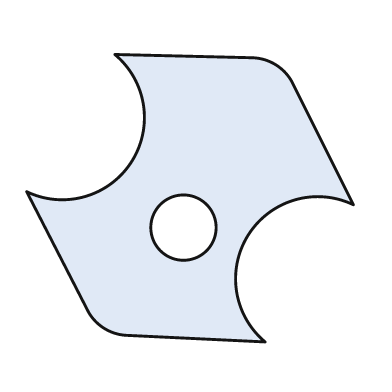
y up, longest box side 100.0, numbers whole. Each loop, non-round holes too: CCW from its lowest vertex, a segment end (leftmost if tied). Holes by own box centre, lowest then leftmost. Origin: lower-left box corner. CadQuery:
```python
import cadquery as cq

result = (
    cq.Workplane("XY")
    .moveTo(73.0, 0.0)
    .threePointArc((68.0, 33.0), (100.0, 42.0))
    .lineTo(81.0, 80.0)
    .threePointArc((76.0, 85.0), (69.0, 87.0))
    .lineTo(27.0, 88.0)
    .threePointArc((32.0, 55.0), (0.0, 46.0))
    .lineTo(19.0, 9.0)
    .threePointArc((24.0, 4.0), (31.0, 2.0))
    .close()
    .moveTo(48.0, 35.0)
    .circle(10.0)
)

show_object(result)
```